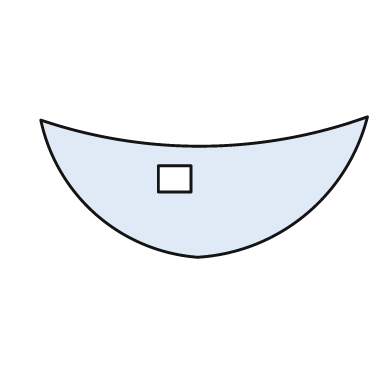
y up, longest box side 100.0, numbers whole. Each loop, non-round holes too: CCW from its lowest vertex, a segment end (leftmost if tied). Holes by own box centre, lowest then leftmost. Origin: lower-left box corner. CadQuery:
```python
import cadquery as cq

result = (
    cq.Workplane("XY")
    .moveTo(48.0, 0.0)
    .threePointArc((81.0, 13.0), (100.0, 43.0))
    .threePointArc((50.0, 34.0), (0.0, 42.0))
    .threePointArc((17.0, 13.0), (48.0, 0.0))
    .close()
    .moveTo(36.0, 20.0)
    .lineTo(46.0, 20.0)
    .lineTo(46.0, 28.0)
    .lineTo(36.0, 28.0)
    .close()
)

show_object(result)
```